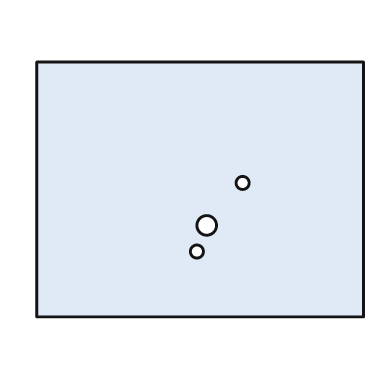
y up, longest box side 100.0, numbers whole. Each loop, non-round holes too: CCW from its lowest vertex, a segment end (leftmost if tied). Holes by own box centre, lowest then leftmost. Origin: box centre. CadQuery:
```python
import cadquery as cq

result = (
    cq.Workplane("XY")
    .moveTo(-50.0, -39.0)
    .lineTo(50.0, -39.0)
    .lineTo(50.0, 39.0)
    .lineTo(-50.0, 39.0)
    .close()
    .moveTo(-1.0, -19.0)
    .circle(2.0)
    .moveTo(2.0, -11.0)
    .circle(3.0)
    .moveTo(13.0, 2.0)
    .circle(2.0)
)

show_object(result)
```